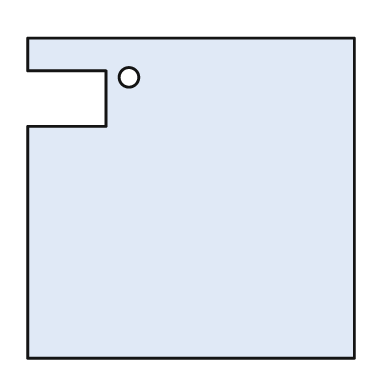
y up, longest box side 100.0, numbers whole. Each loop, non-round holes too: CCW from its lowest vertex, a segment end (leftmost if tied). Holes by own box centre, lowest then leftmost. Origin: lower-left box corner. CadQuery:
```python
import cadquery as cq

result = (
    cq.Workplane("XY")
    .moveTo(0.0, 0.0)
    .lineTo(100.0, 0.0)
    .lineTo(100.0, 98.0)
    .lineTo(0.0, 98.0)
    .lineTo(0.0, 88.0)
    .lineTo(24.0, 88.0)
    .lineTo(24.0, 71.0)
    .lineTo(0.0, 71.0)
    .close()
    .moveTo(31.0, 86.0)
    .circle(3.0)
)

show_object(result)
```